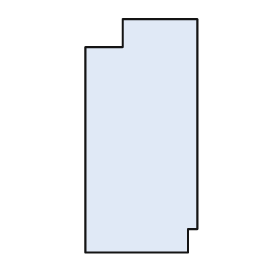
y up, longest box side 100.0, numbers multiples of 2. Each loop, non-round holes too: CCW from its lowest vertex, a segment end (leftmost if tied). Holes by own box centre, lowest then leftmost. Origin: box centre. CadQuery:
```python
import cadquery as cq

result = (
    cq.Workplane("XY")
    .moveTo(-24.0, -50.0)
    .lineTo(20.0, -50.0)
    .lineTo(20.0, -40.0)
    .lineTo(24.0, -40.0)
    .lineTo(24.0, 50.0)
    .lineTo(-8.0, 50.0)
    .lineTo(-8.0, 38.0)
    .lineTo(-24.0, 38.0)
    .close()
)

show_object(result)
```